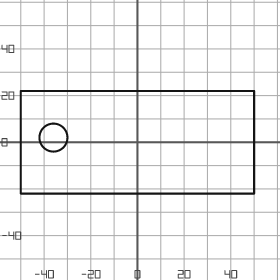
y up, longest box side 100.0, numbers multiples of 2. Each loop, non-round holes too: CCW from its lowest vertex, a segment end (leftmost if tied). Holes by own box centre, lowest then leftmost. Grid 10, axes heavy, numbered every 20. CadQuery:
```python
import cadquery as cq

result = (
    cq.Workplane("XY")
    .moveTo(-50.0, -22.0)
    .lineTo(50.0, -22.0)
    .lineTo(50.0, 22.0)
    .lineTo(-50.0, 22.0)
    .close()
    .moveTo(-36.0, 2.0)
    .circle(6.0)
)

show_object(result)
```